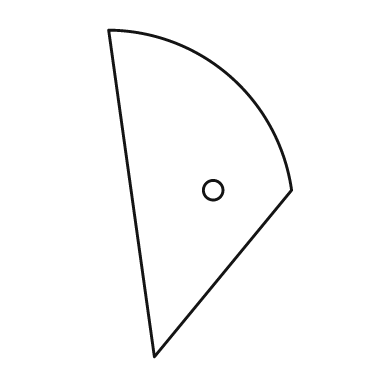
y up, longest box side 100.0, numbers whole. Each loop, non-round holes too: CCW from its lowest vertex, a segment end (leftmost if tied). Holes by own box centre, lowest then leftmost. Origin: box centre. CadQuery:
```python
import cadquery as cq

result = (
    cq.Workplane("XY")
    .moveTo(-14.0, -50.0)
    .lineTo(28.0, 1.0)
    .threePointArc((9.0, 36.0), (-28.0, 50.0))
    .close()
    .moveTo(4.0, 1.0)
    .circle(3.0)
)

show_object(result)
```